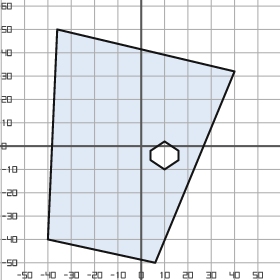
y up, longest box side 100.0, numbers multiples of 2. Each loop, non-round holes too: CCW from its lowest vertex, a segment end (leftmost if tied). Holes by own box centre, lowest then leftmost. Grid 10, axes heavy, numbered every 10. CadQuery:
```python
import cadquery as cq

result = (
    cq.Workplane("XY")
    .moveTo(6.0, -50.0)
    .lineTo(40.0, 32.0)
    .lineTo(-36.0, 50.0)
    .lineTo(-40.0, -40.0)
    .close()
    .moveTo(10.0, -10.0)
    .lineTo(16.0, -6.0)
    .lineTo(16.0, -2.0)
    .lineTo(10.0, 2.0)
    .lineTo(4.0, -2.0)
    .lineTo(4.0, -6.0)
    .close()
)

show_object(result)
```